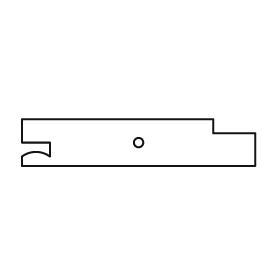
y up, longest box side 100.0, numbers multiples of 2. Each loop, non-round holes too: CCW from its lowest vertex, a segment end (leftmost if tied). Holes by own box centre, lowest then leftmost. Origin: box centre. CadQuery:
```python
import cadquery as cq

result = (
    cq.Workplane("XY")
    .moveTo(-50.0, -10.0)
    .lineTo(50.0, -10.0)
    .lineTo(50.0, 4.0)
    .lineTo(32.0, 4.0)
    .lineTo(32.0, 10.0)
    .lineTo(-50.0, 10.0)
    .lineTo(-50.0, 0.0)
    .lineTo(-38.0, 0.0)
    .lineTo(-38.0, -6.0)
    .threePointArc((-44.0, -4.0), (-50.0, -6.0))
    .close()
    .moveTo(0.0, 0.0)
    .circle(2.0)
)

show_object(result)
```